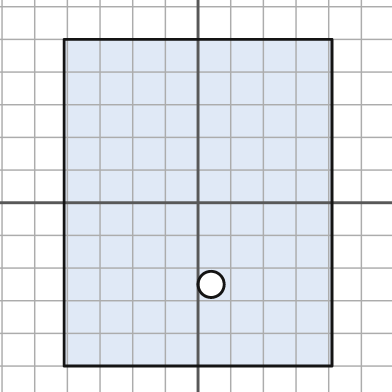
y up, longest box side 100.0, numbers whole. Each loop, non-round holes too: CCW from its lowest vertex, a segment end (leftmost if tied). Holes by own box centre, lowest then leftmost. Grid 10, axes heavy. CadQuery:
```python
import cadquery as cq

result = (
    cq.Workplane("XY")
    .moveTo(-41.0, -50.0)
    .lineTo(41.0, -50.0)
    .lineTo(41.0, 50.0)
    .lineTo(-41.0, 50.0)
    .close()
    .moveTo(4.0, -25.0)
    .circle(4.0)
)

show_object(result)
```